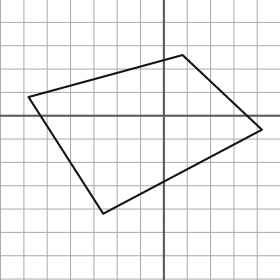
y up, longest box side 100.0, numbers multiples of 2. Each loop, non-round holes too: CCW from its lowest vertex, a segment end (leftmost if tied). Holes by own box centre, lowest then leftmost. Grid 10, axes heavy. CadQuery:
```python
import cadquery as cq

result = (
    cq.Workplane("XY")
    .moveTo(-26.0, -42.0)
    .lineTo(42.0, -6.0)
    .lineTo(8.0, 26.0)
    .lineTo(-58.0, 8.0)
    .close()
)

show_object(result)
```